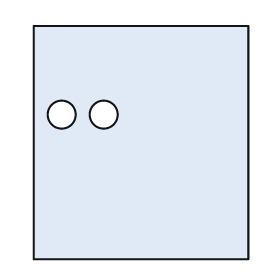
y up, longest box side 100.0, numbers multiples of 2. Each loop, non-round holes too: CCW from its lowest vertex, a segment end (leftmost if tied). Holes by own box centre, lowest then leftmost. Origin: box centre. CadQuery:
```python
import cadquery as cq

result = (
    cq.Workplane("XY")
    .moveTo(-46.0, -50.0)
    .lineTo(46.0, -50.0)
    .lineTo(46.0, 50.0)
    .lineTo(-46.0, 50.0)
    .close()
    .moveTo(-34.0, 12.0)
    .circle(6.0)
    .moveTo(-16.0, 12.0)
    .circle(6.0)
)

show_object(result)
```